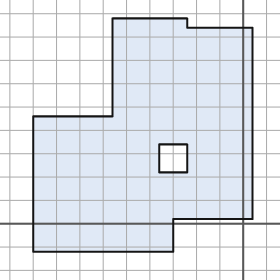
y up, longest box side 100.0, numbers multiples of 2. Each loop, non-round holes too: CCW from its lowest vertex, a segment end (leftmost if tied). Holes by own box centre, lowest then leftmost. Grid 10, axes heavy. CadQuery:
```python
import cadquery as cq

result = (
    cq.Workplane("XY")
    .moveTo(-90.0, -12.0)
    .lineTo(-30.0, -12.0)
    .lineTo(-30.0, 2.0)
    .lineTo(4.0, 2.0)
    .lineTo(4.0, 84.0)
    .lineTo(-24.0, 84.0)
    .lineTo(-24.0, 88.0)
    .lineTo(-56.0, 88.0)
    .lineTo(-56.0, 46.0)
    .lineTo(-90.0, 46.0)
    .close()
    .moveTo(-36.0, 22.0)
    .lineTo(-24.0, 22.0)
    .lineTo(-24.0, 34.0)
    .lineTo(-36.0, 34.0)
    .close()
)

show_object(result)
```